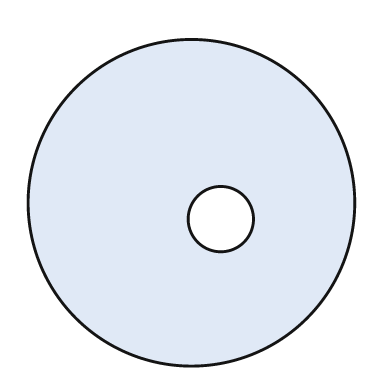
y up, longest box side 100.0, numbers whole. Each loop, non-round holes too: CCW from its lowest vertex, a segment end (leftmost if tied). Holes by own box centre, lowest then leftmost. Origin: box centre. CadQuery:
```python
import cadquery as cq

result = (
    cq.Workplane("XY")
    .moveTo(0.0, 0.0)
    .circle(50.0)
    .moveTo(9.0, -5.0)
    .circle(10.0)
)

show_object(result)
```